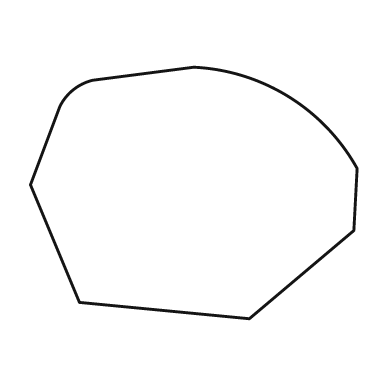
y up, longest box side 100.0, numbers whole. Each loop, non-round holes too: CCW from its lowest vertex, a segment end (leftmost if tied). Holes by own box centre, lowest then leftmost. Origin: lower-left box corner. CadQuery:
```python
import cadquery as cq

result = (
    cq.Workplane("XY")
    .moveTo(67.0, 0.0)
    .lineTo(99.0, 27.0)
    .lineTo(100.0, 46.0)
    .threePointArc((79.0, 68.0), (50.0, 77.0))
    .lineTo(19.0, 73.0)
    .threePointArc((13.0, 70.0), (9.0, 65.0))
    .lineTo(0.0, 41.0)
    .lineTo(15.0, 5.0)
    .close()
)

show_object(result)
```